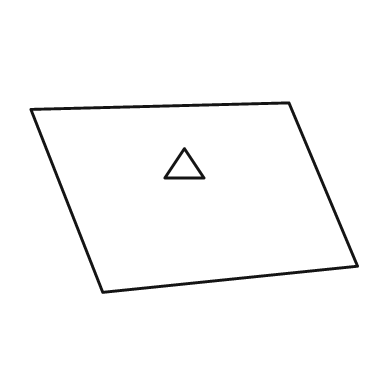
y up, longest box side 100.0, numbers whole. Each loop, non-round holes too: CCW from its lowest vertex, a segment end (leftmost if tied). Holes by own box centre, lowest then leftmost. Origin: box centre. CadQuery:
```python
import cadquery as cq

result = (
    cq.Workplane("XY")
    .moveTo(-28.0, -29.0)
    .lineTo(50.0, -21.0)
    .lineTo(29.0, 29.0)
    .lineTo(-50.0, 27.0)
    .close()
    .moveTo(-9.0, 6.0)
    .lineTo(3.0, 6.0)
    .lineTo(-3.0, 15.0)
    .close()
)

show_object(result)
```